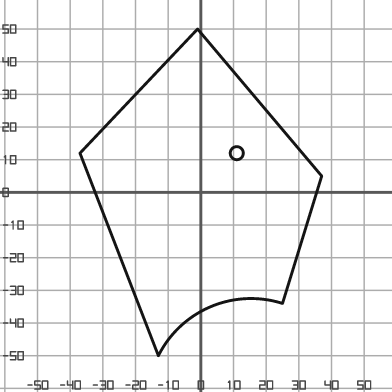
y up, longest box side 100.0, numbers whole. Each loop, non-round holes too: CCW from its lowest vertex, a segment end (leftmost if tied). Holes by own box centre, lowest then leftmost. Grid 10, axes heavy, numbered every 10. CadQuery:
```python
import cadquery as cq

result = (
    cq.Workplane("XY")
    .moveTo(-13.0, -50.0)
    .threePointArc((3.0, -35.0), (25.0, -34.0))
    .lineTo(37.0, 5.0)
    .lineTo(-1.0, 50.0)
    .lineTo(-37.0, 12.0)
    .close()
    .moveTo(11.0, 12.0)
    .circle(2.0)
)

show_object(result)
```